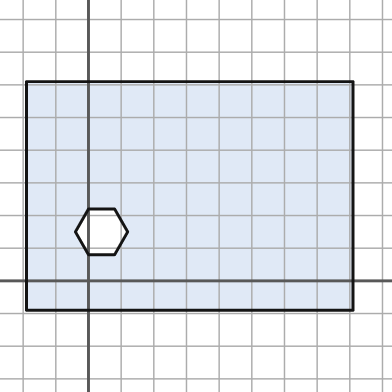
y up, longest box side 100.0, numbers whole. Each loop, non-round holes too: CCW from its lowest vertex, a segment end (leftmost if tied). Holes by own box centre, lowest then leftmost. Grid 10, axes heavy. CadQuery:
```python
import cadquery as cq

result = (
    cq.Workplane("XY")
    .moveTo(-19.0, -9.0)
    .lineTo(81.0, -9.0)
    .lineTo(81.0, 61.0)
    .lineTo(-19.0, 61.0)
    .close()
    .moveTo(0.0, 8.0)
    .lineTo(8.0, 8.0)
    .lineTo(12.0, 15.0)
    .lineTo(8.0, 22.0)
    .lineTo(0.0, 22.0)
    .lineTo(-4.0, 15.0)
    .close()
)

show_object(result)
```